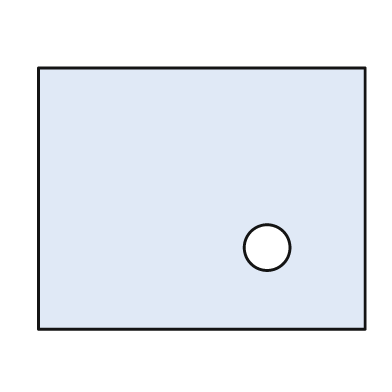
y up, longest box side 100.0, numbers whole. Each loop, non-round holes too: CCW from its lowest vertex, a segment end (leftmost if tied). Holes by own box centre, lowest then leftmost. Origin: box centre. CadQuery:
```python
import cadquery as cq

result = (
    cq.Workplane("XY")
    .moveTo(-50.0, -40.0)
    .lineTo(50.0, -40.0)
    .lineTo(50.0, 40.0)
    .lineTo(-50.0, 40.0)
    .close()
    .moveTo(20.0, -15.0)
    .circle(7.0)
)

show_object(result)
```